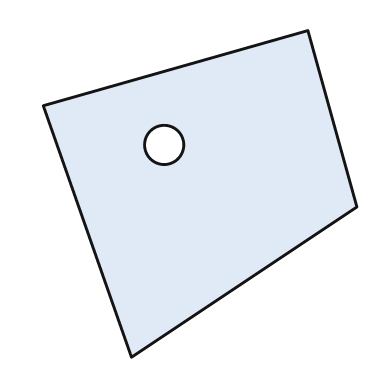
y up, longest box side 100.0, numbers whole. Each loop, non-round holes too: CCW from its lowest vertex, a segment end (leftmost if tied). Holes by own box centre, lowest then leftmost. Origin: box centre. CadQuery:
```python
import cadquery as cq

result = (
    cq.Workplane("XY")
    .moveTo(-21.0, -50.0)
    .lineTo(48.0, -4.0)
    .lineTo(33.0, 50.0)
    .lineTo(-48.0, 27.0)
    .close()
    .moveTo(-11.0, 15.0)
    .circle(6.0)
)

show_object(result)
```